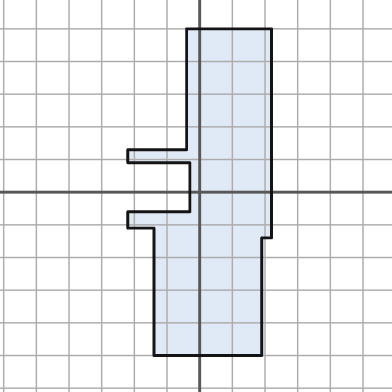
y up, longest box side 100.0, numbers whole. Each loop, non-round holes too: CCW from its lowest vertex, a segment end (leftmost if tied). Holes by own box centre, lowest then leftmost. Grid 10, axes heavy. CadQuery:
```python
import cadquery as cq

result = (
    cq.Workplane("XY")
    .moveTo(-14.0, -50.0)
    .lineTo(19.0, -50.0)
    .lineTo(19.0, -14.0)
    .lineTo(22.0, -14.0)
    .lineTo(22.0, 50.0)
    .lineTo(-4.0, 50.0)
    .lineTo(-4.0, 13.0)
    .lineTo(-22.0, 13.0)
    .lineTo(-22.0, 9.0)
    .lineTo(-3.0, 9.0)
    .lineTo(-3.0, -6.0)
    .lineTo(-22.0, -6.0)
    .lineTo(-22.0, -11.0)
    .lineTo(-14.0, -11.0)
    .close()
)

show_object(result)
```